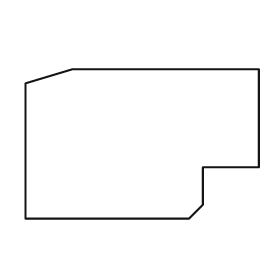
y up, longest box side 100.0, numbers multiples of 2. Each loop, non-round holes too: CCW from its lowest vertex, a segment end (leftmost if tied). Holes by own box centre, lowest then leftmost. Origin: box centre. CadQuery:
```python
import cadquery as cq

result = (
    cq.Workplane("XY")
    .moveTo(-50.0, -32.0)
    .lineTo(20.0, -32.0)
    .lineTo(26.0, -26.0)
    .lineTo(26.0, -10.0)
    .lineTo(50.0, -10.0)
    .lineTo(50.0, 32.0)
    .lineTo(-30.0, 32.0)
    .lineTo(-50.0, 26.0)
    .close()
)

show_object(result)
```